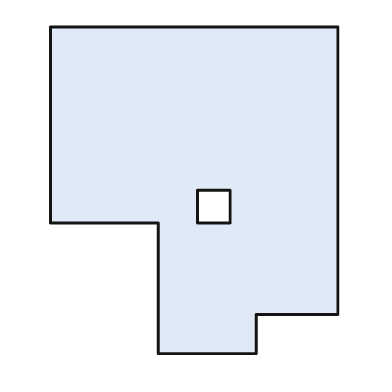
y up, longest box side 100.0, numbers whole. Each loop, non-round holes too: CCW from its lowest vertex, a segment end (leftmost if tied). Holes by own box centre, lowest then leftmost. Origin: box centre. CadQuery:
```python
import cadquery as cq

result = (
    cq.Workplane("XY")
    .moveTo(-11.0, -50.0)
    .lineTo(19.0, -50.0)
    .lineTo(19.0, -38.0)
    .lineTo(44.0, -38.0)
    .lineTo(44.0, 50.0)
    .lineTo(-44.0, 50.0)
    .lineTo(-44.0, -10.0)
    .lineTo(-11.0, -10.0)
    .close()
    .moveTo(1.0, -10.0)
    .lineTo(11.0, -10.0)
    .lineTo(11.0, 0.0)
    .lineTo(1.0, 0.0)
    .close()
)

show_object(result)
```